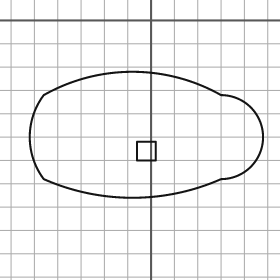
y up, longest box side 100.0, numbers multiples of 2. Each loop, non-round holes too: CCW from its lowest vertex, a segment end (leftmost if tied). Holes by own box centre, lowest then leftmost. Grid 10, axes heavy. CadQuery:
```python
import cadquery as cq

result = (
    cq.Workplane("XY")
    .moveTo(-46.0, -68.0)
    .threePointArc((-8.0, -76.0), (30.0, -68.0))
    .threePointArc((48.0, -50.0), (30.0, -32.0))
    .threePointArc((-8.0, -22.0), (-46.0, -32.0))
    .threePointArc((-52.0, -50.0), (-46.0, -68.0))
    .close()
    .moveTo(-6.0, -60.0)
    .lineTo(2.0, -60.0)
    .lineTo(2.0, -52.0)
    .lineTo(-6.0, -52.0)
    .close()
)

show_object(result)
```